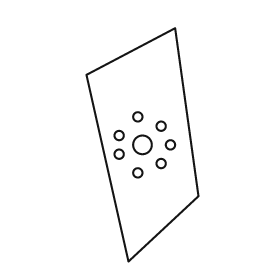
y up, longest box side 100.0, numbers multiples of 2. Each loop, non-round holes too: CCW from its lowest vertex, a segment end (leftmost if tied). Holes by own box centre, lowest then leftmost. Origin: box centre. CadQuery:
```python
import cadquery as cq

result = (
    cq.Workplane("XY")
    .moveTo(-6.0, -50.0)
    .lineTo(24.0, -22.0)
    .lineTo(14.0, 50.0)
    .lineTo(-24.0, 30.0)
    .close()
    .moveTo(-2.0, -12.0)
    .circle(2.0)
    .moveTo(8.0, -8.0)
    .circle(2.0)
    .moveTo(-10.0, -4.0)
    .circle(2.0)
    .moveTo(0.0, 0.0)
    .circle(4.0)
    .moveTo(12.0, 0.0)
    .circle(2.0)
    .moveTo(-10.0, 4.0)
    .circle(2.0)
    .moveTo(8.0, 8.0)
    .circle(2.0)
    .moveTo(-2.0, 12.0)
    .circle(2.0)
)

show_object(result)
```